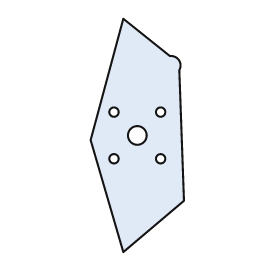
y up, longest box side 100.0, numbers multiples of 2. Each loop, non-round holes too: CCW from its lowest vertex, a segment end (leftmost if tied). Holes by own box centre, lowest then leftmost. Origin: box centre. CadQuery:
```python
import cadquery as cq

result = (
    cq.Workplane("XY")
    .moveTo(-6.0, -50.0)
    .lineTo(20.0, -28.0)
    .lineTo(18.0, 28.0)
    .threePointArc((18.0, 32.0), (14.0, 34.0))
    .lineTo(-6.0, 50.0)
    .lineTo(-20.0, -2.0)
    .close()
    .moveTo(-10.0, -10.0)
    .circle(2.0)
    .moveTo(10.0, -10.0)
    .circle(2.0)
    .moveTo(0.0, 0.0)
    .circle(4.0)
    .moveTo(-10.0, 10.0)
    .circle(2.0)
    .moveTo(10.0, 10.0)
    .circle(2.0)
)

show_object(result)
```